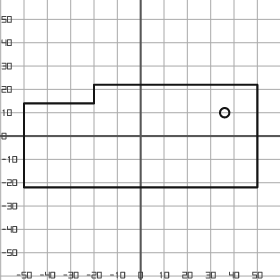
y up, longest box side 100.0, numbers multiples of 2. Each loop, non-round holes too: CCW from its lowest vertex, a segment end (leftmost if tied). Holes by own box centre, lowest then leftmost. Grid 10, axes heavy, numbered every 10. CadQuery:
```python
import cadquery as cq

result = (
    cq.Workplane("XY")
    .moveTo(-50.0, -22.0)
    .lineTo(50.0, -22.0)
    .lineTo(50.0, 22.0)
    .lineTo(-20.0, 22.0)
    .lineTo(-20.0, 14.0)
    .lineTo(-50.0, 14.0)
    .close()
    .moveTo(36.0, 10.0)
    .circle(2.0)
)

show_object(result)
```